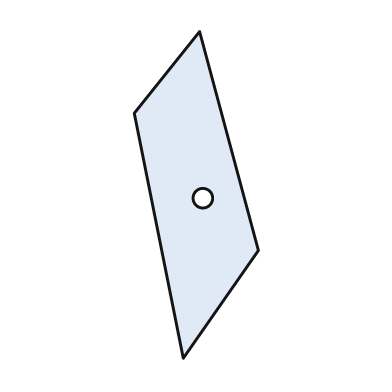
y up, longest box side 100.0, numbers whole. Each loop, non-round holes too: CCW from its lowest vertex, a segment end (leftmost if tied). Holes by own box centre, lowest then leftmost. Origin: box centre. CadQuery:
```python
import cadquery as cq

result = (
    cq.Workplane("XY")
    .moveTo(-4.0, -50.0)
    .lineTo(19.0, -17.0)
    .lineTo(1.0, 50.0)
    .lineTo(-19.0, 25.0)
    .close()
    .moveTo(2.0, -1.0)
    .circle(3.0)
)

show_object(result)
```